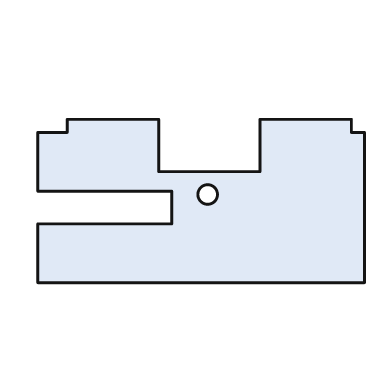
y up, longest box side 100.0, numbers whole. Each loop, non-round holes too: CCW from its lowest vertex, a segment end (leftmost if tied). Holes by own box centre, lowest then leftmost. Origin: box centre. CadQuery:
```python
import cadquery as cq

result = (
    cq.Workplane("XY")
    .moveTo(-50.0, -25.0)
    .lineTo(50.0, -25.0)
    .lineTo(50.0, 21.0)
    .lineTo(46.0, 21.0)
    .lineTo(46.0, 25.0)
    .lineTo(18.0, 25.0)
    .lineTo(18.0, 9.0)
    .lineTo(-13.0, 9.0)
    .lineTo(-13.0, 25.0)
    .lineTo(-41.0, 25.0)
    .lineTo(-41.0, 21.0)
    .lineTo(-50.0, 21.0)
    .lineTo(-50.0, 3.0)
    .lineTo(-9.0, 3.0)
    .lineTo(-9.0, -7.0)
    .lineTo(-50.0, -7.0)
    .close()
    .moveTo(2.0, 2.0)
    .circle(3.0)
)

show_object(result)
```